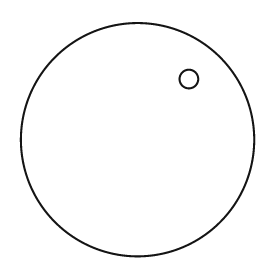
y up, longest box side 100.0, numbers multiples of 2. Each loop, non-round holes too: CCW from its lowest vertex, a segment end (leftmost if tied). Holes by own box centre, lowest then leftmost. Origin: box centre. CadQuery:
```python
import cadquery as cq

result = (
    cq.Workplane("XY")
    .moveTo(0.0, 0.0)
    .circle(50.0)
    .moveTo(22.0, 26.0)
    .circle(4.0)
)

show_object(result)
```